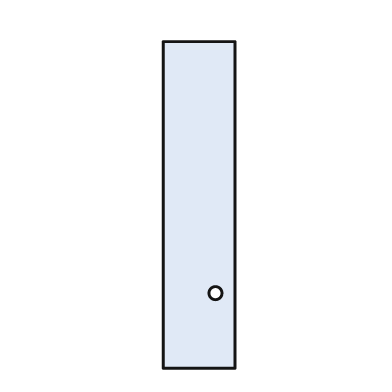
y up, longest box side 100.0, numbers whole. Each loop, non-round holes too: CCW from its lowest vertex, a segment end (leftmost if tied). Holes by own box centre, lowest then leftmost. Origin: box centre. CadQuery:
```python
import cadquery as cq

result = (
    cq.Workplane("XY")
    .moveTo(-11.0, -50.0)
    .lineTo(11.0, -50.0)
    .lineTo(11.0, 50.0)
    .lineTo(-11.0, 50.0)
    .close()
    .moveTo(5.0, -27.0)
    .circle(2.0)
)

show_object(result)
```